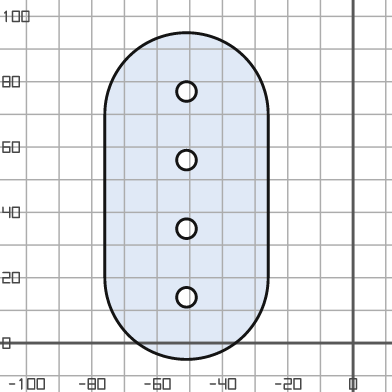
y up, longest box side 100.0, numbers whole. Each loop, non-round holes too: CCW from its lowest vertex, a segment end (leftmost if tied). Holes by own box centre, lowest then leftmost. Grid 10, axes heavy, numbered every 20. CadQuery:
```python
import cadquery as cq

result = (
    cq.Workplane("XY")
    .moveTo(-76.0, 20.0)
    .threePointArc((-51.0, -5.0), (-26.0, 20.0))
    .lineTo(-26.0, 70.0)
    .threePointArc((-51.0, 95.0), (-76.0, 70.0))
    .close()
    .moveTo(-51.0, 14.0)
    .circle(3.0)
    .moveTo(-51.0, 35.0)
    .circle(3.0)
    .moveTo(-51.0, 56.0)
    .circle(3.0)
    .moveTo(-51.0, 77.0)
    .circle(3.0)
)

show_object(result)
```